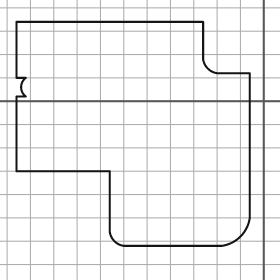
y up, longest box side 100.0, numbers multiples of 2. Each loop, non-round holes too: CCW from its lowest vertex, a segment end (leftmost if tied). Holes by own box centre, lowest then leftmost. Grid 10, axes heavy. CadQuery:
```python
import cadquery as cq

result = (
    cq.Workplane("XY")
    .moveTo(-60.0, -62.0)
    .lineTo(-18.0, -62.0)
    .threePointArc((-10.0, -58.0), (-6.0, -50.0))
    .lineTo(-6.0, 12.0)
    .lineTo(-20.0, 12.0)
    .threePointArc((-24.0, 14.0), (-26.0, 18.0))
    .lineTo(-26.0, 34.0)
    .lineTo(-106.0, 34.0)
    .lineTo(-106.0, 10.0)
    .lineTo(-102.0, 10.0)
    .threePointArc((-104.0, 6.0), (-102.0, 2.0))
    .lineTo(-106.0, 2.0)
    .lineTo(-106.0, -30.0)
    .lineTo(-66.0, -30.0)
    .lineTo(-66.0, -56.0)
    .threePointArc((-64.0, -60.0), (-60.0, -62.0))
    .close()
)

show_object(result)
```